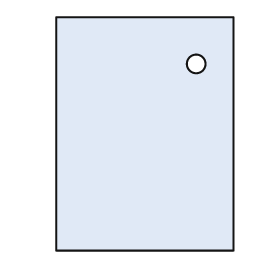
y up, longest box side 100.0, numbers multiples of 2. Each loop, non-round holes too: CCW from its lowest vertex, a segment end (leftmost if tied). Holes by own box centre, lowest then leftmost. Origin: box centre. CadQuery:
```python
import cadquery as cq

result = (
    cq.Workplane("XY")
    .moveTo(-38.0, -50.0)
    .lineTo(38.0, -50.0)
    .lineTo(38.0, 50.0)
    .lineTo(-38.0, 50.0)
    .close()
    .moveTo(22.0, 30.0)
    .circle(4.0)
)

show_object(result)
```